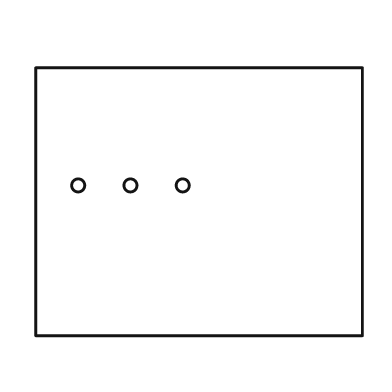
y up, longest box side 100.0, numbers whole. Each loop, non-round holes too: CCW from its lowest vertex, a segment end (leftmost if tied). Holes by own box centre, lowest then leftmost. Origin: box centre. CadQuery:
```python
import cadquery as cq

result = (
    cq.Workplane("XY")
    .moveTo(-50.0, -41.0)
    .lineTo(50.0, -41.0)
    .lineTo(50.0, 41.0)
    .lineTo(-50.0, 41.0)
    .close()
    .moveTo(-37.0, 5.0)
    .circle(2.0)
    .moveTo(-21.0, 5.0)
    .circle(2.0)
    .moveTo(-5.0, 5.0)
    .circle(2.0)
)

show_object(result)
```